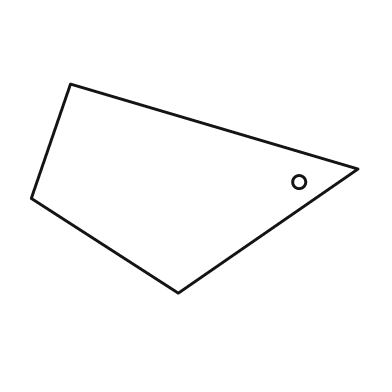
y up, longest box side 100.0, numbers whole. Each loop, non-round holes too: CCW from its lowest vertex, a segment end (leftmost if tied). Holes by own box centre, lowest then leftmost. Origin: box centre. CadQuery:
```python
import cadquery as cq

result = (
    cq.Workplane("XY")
    .moveTo(-5.0, -32.0)
    .lineTo(50.0, 6.0)
    .lineTo(-38.0, 32.0)
    .lineTo(-50.0, -3.0)
    .close()
    .moveTo(32.0, 2.0)
    .circle(2.0)
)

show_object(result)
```